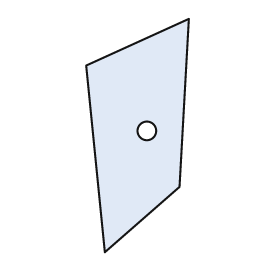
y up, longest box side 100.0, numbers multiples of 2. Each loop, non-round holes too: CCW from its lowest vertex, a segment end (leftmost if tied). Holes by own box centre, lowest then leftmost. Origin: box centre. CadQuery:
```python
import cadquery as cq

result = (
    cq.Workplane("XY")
    .moveTo(-14.0, -50.0)
    .lineTo(18.0, -22.0)
    .lineTo(22.0, 50.0)
    .lineTo(-22.0, 30.0)
    .close()
    .moveTo(4.0, 2.0)
    .circle(4.0)
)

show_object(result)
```